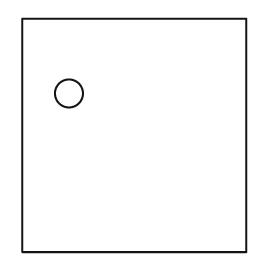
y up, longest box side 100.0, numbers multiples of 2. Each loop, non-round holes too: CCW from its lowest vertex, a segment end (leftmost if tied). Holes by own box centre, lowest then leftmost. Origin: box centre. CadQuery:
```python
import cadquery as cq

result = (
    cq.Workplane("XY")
    .moveTo(-48.0, -50.0)
    .lineTo(48.0, -50.0)
    .lineTo(48.0, 50.0)
    .lineTo(-48.0, 50.0)
    .close()
    .moveTo(-28.0, 18.0)
    .circle(6.0)
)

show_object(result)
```